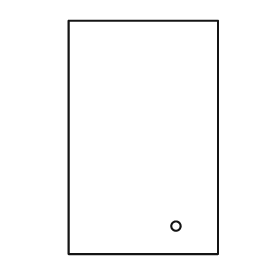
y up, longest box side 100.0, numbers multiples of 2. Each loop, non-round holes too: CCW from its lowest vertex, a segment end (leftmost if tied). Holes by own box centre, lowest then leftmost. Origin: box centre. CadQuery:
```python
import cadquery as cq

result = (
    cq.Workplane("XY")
    .moveTo(-32.0, -50.0)
    .lineTo(32.0, -50.0)
    .lineTo(32.0, 50.0)
    .lineTo(-32.0, 50.0)
    .close()
    .moveTo(14.0, -38.0)
    .circle(2.0)
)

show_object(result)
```